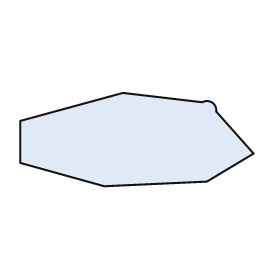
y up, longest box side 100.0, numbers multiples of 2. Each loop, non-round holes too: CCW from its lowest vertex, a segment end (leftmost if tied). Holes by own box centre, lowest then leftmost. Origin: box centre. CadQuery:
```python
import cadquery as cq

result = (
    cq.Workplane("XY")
    .moveTo(-14.0, -20.0)
    .lineTo(30.0, -18.0)
    .lineTo(50.0, -6.0)
    .lineTo(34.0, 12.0)
    .threePointArc((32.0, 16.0), (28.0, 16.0))
    .lineTo(-6.0, 20.0)
    .lineTo(-50.0, 8.0)
    .lineTo(-50.0, -10.0)
    .close()
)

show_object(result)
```